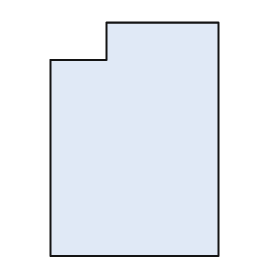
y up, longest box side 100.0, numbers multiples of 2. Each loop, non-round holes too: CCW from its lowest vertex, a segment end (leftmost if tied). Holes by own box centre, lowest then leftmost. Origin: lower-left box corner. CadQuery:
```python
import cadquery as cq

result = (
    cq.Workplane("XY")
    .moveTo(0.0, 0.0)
    .lineTo(72.0, 0.0)
    .lineTo(72.0, 100.0)
    .lineTo(24.0, 100.0)
    .lineTo(24.0, 84.0)
    .lineTo(0.0, 84.0)
    .close()
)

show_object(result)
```